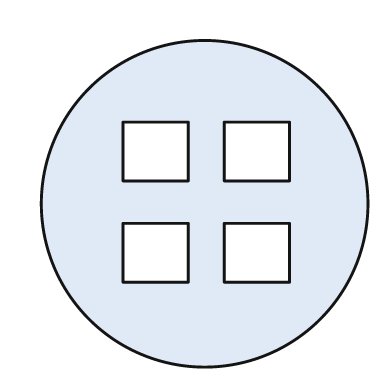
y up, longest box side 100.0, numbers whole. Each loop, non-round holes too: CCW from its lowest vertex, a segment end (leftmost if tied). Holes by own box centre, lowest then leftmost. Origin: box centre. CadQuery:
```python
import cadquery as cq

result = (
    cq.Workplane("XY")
    .moveTo(0.0, 0.0)
    .circle(50.0)
    .moveTo(-25.0, -24.0)
    .lineTo(-5.0, -24.0)
    .lineTo(-5.0, -6.0)
    .lineTo(-25.0, -6.0)
    .close()
    .moveTo(6.0, -24.0)
    .lineTo(26.0, -24.0)
    .lineTo(26.0, -6.0)
    .lineTo(6.0, -6.0)
    .close()
    .moveTo(-25.0, 7.0)
    .lineTo(-5.0, 7.0)
    .lineTo(-5.0, 25.0)
    .lineTo(-25.0, 25.0)
    .close()
    .moveTo(6.0, 7.0)
    .lineTo(26.0, 7.0)
    .lineTo(26.0, 25.0)
    .lineTo(6.0, 25.0)
    .close()
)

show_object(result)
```